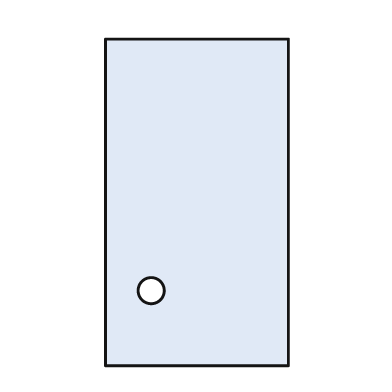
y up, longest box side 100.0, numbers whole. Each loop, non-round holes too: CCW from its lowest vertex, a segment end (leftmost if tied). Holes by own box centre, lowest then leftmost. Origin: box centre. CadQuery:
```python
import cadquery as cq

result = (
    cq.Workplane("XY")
    .moveTo(-28.0, -50.0)
    .lineTo(28.0, -50.0)
    .lineTo(28.0, 50.0)
    .lineTo(-28.0, 50.0)
    .close()
    .moveTo(-14.0, -27.0)
    .circle(4.0)
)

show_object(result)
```